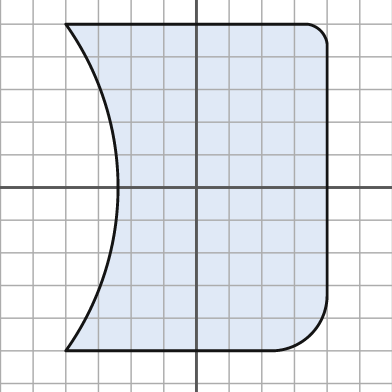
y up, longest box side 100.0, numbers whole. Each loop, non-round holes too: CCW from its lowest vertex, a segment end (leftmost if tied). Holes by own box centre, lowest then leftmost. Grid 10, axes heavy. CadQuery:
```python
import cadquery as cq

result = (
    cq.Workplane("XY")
    .moveTo(-40.0, -50.0)
    .lineTo(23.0, -50.0)
    .threePointArc((35.0, -45.0), (40.0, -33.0))
    .lineTo(40.0, 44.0)
    .threePointArc((38.0, 48.0), (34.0, 50.0))
    .lineTo(-40.0, 50.0)
    .threePointArc((-24.0, 0.0), (-40.0, -50.0))
    .close()
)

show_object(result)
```